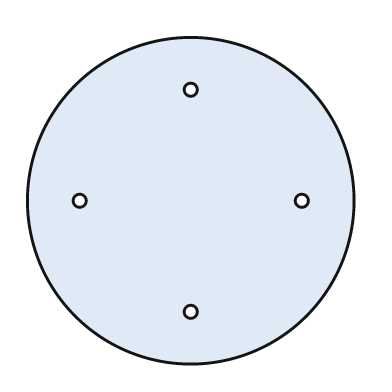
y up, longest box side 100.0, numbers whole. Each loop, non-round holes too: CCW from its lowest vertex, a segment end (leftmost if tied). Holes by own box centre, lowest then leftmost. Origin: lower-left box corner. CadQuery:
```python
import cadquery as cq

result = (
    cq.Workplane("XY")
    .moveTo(50.0, 50.0)
    .circle(50.0)
    .moveTo(50.0, 16.0)
    .circle(2.0)
    .moveTo(16.0, 50.0)
    .circle(2.0)
    .moveTo(84.0, 50.0)
    .circle(2.0)
    .moveTo(50.0, 84.0)
    .circle(2.0)
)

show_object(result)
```